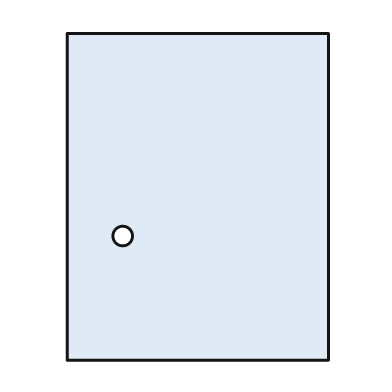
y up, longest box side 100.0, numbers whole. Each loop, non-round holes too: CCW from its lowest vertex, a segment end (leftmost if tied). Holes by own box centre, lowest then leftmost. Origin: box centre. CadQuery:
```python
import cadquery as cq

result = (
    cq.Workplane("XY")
    .moveTo(-40.0, -50.0)
    .lineTo(40.0, -50.0)
    .lineTo(40.0, 50.0)
    .lineTo(-40.0, 50.0)
    .close()
    .moveTo(-23.0, -12.0)
    .circle(3.0)
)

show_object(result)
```